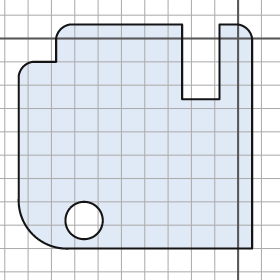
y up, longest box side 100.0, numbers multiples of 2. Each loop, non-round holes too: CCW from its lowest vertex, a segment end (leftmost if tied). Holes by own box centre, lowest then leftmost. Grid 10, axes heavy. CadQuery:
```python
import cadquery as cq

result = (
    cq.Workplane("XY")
    .moveTo(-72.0, -90.0)
    .lineTo(6.0, -90.0)
    .lineTo(6.0, 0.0)
    .threePointArc((4.0, 4.0), (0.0, 6.0))
    .lineTo(-8.0, 6.0)
    .lineTo(-8.0, -26.0)
    .lineTo(-24.0, -26.0)
    .lineTo(-24.0, 6.0)
    .lineTo(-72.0, 6.0)
    .threePointArc((-76.0, 4.0), (-78.0, 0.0))
    .lineTo(-78.0, -10.0)
    .lineTo(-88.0, -10.0)
    .threePointArc((-92.0, -12.0), (-94.0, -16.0))
    .lineTo(-94.0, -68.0)
    .threePointArc((-88.0, -84.0), (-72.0, -90.0))
    .close()
    .moveTo(-66.0, -78.0)
    .circle(8.0)
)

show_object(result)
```